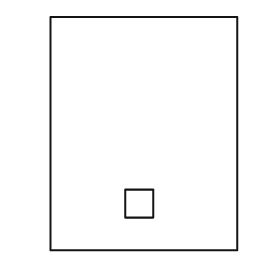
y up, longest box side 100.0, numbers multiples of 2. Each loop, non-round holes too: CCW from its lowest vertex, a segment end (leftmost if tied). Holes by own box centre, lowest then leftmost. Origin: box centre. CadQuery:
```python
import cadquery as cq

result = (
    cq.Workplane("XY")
    .moveTo(-40.0, -50.0)
    .lineTo(40.0, -50.0)
    .lineTo(40.0, 50.0)
    .lineTo(-40.0, 50.0)
    .close()
    .moveTo(-8.0, -36.0)
    .lineTo(4.0, -36.0)
    .lineTo(4.0, -24.0)
    .lineTo(-8.0, -24.0)
    .close()
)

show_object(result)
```